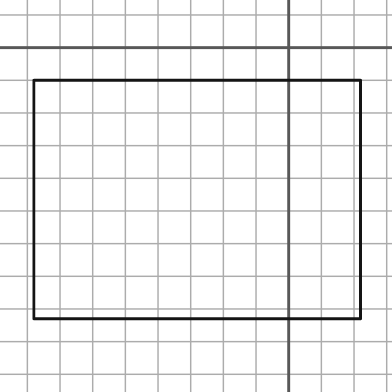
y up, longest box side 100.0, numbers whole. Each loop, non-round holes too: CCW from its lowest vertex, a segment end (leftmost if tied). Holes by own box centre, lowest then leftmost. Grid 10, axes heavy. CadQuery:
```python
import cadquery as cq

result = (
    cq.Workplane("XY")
    .moveTo(-78.0, -83.0)
    .lineTo(22.0, -83.0)
    .lineTo(22.0, -10.0)
    .lineTo(-78.0, -10.0)
    .close()
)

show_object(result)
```